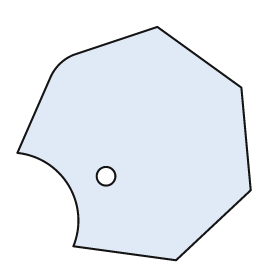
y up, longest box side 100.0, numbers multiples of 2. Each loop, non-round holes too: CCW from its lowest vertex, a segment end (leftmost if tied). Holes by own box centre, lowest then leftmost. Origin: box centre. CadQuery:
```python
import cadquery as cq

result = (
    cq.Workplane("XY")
    .moveTo(18.0, -50.0)
    .lineTo(50.0, -20.0)
    .lineTo(46.0, 24.0)
    .lineTo(10.0, 50.0)
    .lineTo(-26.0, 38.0)
    .threePointArc((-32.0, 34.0), (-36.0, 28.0))
    .lineTo(-50.0, -4.0)
    .threePointArc((-28.0, -18.0), (-26.0, -44.0))
    .close()
    .moveTo(-12.0, -14.0)
    .circle(4.0)
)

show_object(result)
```